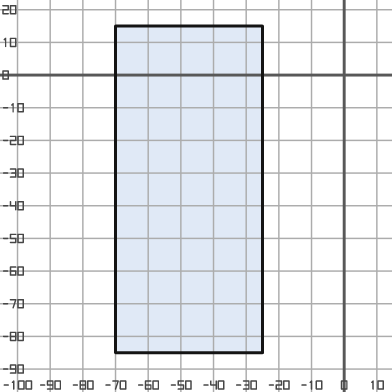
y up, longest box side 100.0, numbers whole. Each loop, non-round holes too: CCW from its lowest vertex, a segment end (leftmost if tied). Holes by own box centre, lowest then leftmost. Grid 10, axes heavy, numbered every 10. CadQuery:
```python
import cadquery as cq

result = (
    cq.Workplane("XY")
    .moveTo(-70.0, -85.0)
    .lineTo(-25.0, -85.0)
    .lineTo(-25.0, 15.0)
    .lineTo(-70.0, 15.0)
    .close()
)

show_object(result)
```